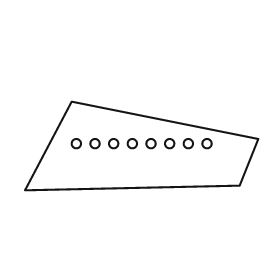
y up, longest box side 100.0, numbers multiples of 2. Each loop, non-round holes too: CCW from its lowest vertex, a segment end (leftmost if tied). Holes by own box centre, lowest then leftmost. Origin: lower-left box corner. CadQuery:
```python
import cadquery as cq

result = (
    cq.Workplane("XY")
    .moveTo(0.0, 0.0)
    .lineTo(92.0, 2.0)
    .lineTo(100.0, 22.0)
    .lineTo(20.0, 38.0)
    .close()
    .moveTo(22.0, 20.0)
    .circle(2.0)
    .moveTo(30.0, 20.0)
    .circle(2.0)
    .moveTo(38.0, 20.0)
    .circle(2.0)
    .moveTo(46.0, 20.0)
    .circle(2.0)
    .moveTo(54.0, 20.0)
    .circle(2.0)
    .moveTo(62.0, 20.0)
    .circle(2.0)
    .moveTo(70.0, 20.0)
    .circle(2.0)
    .moveTo(78.0, 20.0)
    .circle(2.0)
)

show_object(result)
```